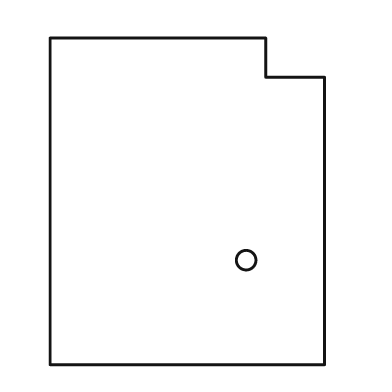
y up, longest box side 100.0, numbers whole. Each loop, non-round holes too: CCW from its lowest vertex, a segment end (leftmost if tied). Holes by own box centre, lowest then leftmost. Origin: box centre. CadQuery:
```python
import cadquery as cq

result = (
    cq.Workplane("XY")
    .moveTo(-42.0, -50.0)
    .lineTo(42.0, -50.0)
    .lineTo(42.0, 38.0)
    .lineTo(24.0, 38.0)
    .lineTo(24.0, 50.0)
    .lineTo(-42.0, 50.0)
    .close()
    .moveTo(18.0, -18.0)
    .circle(3.0)
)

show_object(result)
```